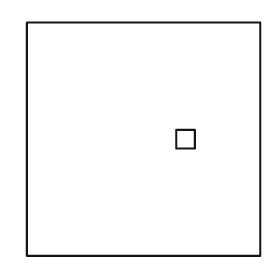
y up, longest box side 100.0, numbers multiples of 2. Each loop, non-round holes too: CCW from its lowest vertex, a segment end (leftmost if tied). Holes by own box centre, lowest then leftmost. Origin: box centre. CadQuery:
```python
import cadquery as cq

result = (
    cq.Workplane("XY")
    .moveTo(-50.0, -50.0)
    .lineTo(50.0, -50.0)
    .lineTo(50.0, 50.0)
    .lineTo(-50.0, 50.0)
    .close()
    .moveTo(14.0, -4.0)
    .lineTo(22.0, -4.0)
    .lineTo(22.0, 4.0)
    .lineTo(14.0, 4.0)
    .close()
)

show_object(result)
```